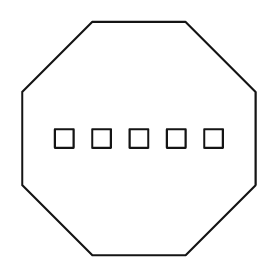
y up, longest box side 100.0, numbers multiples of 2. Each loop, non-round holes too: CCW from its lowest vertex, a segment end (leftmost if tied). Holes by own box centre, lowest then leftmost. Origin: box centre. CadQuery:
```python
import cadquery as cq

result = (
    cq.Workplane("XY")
    .moveTo(-20.0, -50.0)
    .lineTo(20.0, -50.0)
    .lineTo(50.0, -20.0)
    .lineTo(50.0, 20.0)
    .lineTo(20.0, 50.0)
    .lineTo(-20.0, 50.0)
    .lineTo(-50.0, 20.0)
    .lineTo(-50.0, -20.0)
    .close()
    .moveTo(-36.0, -4.0)
    .lineTo(-28.0, -4.0)
    .lineTo(-28.0, 4.0)
    .lineTo(-36.0, 4.0)
    .close()
    .moveTo(-20.0, -4.0)
    .lineTo(-12.0, -4.0)
    .lineTo(-12.0, 4.0)
    .lineTo(-20.0, 4.0)
    .close()
    .moveTo(-4.0, -4.0)
    .lineTo(4.0, -4.0)
    .lineTo(4.0, 4.0)
    .lineTo(-4.0, 4.0)
    .close()
    .moveTo(12.0, -4.0)
    .lineTo(20.0, -4.0)
    .lineTo(20.0, 4.0)
    .lineTo(12.0, 4.0)
    .close()
    .moveTo(28.0, -4.0)
    .lineTo(36.0, -4.0)
    .lineTo(36.0, 4.0)
    .lineTo(28.0, 4.0)
    .close()
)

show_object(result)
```